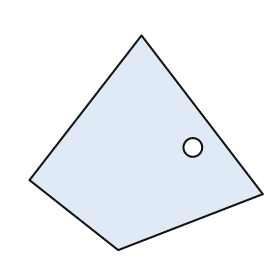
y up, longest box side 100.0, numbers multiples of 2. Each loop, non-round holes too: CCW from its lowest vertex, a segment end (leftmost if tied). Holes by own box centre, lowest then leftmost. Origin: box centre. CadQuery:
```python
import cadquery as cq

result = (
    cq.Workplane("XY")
    .moveTo(-12.0, -46.0)
    .lineTo(50.0, -22.0)
    .lineTo(-2.0, 46.0)
    .lineTo(-50.0, -16.0)
    .close()
    .moveTo(20.0, -2.0)
    .circle(4.0)
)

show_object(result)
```